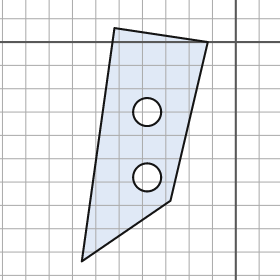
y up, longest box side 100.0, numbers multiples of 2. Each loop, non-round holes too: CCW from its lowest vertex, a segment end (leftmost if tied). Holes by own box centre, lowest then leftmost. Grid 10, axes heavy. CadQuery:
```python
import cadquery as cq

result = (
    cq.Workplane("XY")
    .moveTo(-66.0, -94.0)
    .lineTo(-28.0, -68.0)
    .lineTo(-12.0, 0.0)
    .lineTo(-52.0, 6.0)
    .close()
    .moveTo(-38.0, -58.0)
    .circle(6.0)
    .moveTo(-38.0, -30.0)
    .circle(6.0)
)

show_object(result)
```